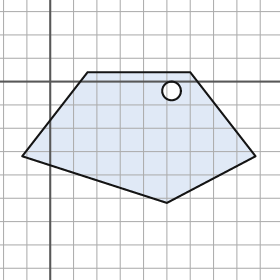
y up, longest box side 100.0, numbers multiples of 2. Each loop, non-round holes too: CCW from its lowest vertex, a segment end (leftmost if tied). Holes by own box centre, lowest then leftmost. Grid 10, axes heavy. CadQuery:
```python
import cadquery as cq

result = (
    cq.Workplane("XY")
    .moveTo(50.0, -52.0)
    .lineTo(88.0, -32.0)
    .lineTo(60.0, 4.0)
    .lineTo(16.0, 4.0)
    .lineTo(-12.0, -32.0)
    .close()
    .moveTo(52.0, -4.0)
    .circle(4.0)
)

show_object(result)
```